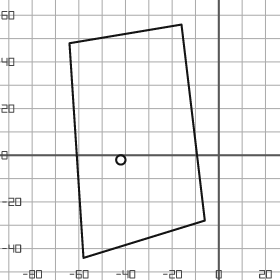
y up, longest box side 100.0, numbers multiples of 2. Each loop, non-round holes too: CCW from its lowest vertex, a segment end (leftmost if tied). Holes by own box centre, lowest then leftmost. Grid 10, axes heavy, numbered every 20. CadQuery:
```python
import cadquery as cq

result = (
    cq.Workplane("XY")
    .moveTo(-58.0, -44.0)
    .lineTo(-6.0, -28.0)
    .lineTo(-16.0, 56.0)
    .lineTo(-64.0, 48.0)
    .close()
    .moveTo(-42.0, -2.0)
    .circle(2.0)
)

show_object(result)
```